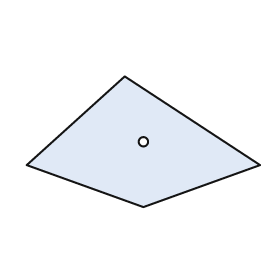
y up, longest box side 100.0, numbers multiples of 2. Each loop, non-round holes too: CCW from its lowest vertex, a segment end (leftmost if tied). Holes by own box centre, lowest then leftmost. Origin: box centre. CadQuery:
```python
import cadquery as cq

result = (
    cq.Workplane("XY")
    .moveTo(0.0, -28.0)
    .lineTo(50.0, -10.0)
    .lineTo(-8.0, 28.0)
    .lineTo(-50.0, -10.0)
    .close()
    .moveTo(0.0, 0.0)
    .circle(2.0)
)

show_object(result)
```